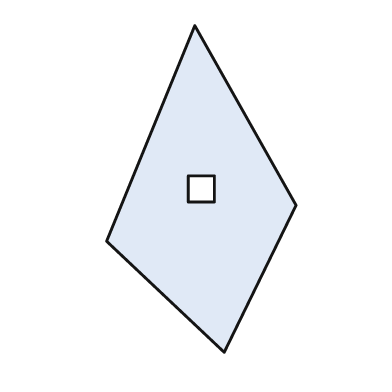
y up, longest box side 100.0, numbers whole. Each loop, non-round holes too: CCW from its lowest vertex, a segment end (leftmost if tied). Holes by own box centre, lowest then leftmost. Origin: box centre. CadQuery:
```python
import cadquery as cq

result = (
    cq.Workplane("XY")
    .moveTo(7.0, -50.0)
    .lineTo(29.0, -5.0)
    .lineTo(-2.0, 50.0)
    .lineTo(-29.0, -16.0)
    .close()
    .moveTo(-4.0, -4.0)
    .lineTo(4.0, -4.0)
    .lineTo(4.0, 4.0)
    .lineTo(-4.0, 4.0)
    .close()
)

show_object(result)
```